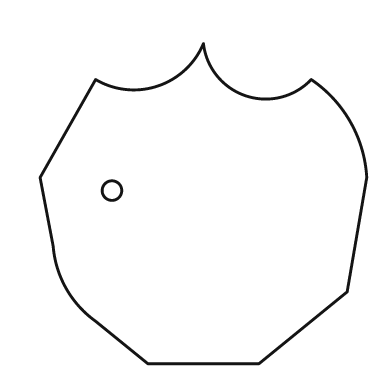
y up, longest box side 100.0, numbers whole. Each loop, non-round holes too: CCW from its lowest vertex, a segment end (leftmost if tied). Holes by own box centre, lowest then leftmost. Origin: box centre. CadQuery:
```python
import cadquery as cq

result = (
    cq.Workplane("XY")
    .moveTo(-17.0, -49.0)
    .lineTo(17.0, -49.0)
    .lineTo(44.0, -27.0)
    .lineTo(50.0, 8.0)
    .threePointArc((45.0, 25.0), (33.0, 38.0))
    .threePointArc((13.0, 33.0), (0.0, 49.0))
    .threePointArc((-14.0, 36.0), (-33.0, 38.0))
    .lineTo(-50.0, 8.0)
    .lineTo(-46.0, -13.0)
    .threePointArc((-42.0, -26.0), (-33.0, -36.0))
    .close()
    .moveTo(-28.0, 4.0)
    .circle(3.0)
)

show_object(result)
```